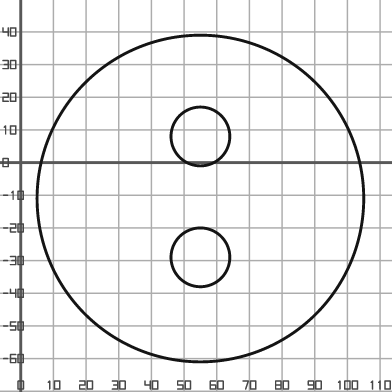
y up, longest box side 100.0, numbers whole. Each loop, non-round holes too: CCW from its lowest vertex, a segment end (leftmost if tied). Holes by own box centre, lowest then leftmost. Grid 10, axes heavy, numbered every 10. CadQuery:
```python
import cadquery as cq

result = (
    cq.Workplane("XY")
    .moveTo(55.0, -11.0)
    .circle(50.0)
    .moveTo(55.0, -29.0)
    .circle(9.0)
    .moveTo(55.0, 8.0)
    .circle(9.0)
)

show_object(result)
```